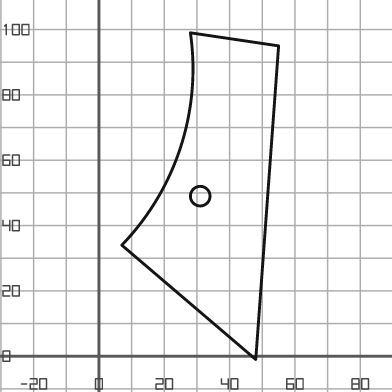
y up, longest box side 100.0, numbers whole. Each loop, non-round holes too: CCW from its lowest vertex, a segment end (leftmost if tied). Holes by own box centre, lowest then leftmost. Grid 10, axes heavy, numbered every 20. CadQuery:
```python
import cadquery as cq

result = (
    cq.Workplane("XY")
    .moveTo(48.0, -1.0)
    .lineTo(55.0, 95.0)
    .lineTo(28.0, 99.0)
    .threePointArc((25.0, 64.0), (7.0, 34.0))
    .close()
    .moveTo(31.0, 49.0)
    .circle(3.0)
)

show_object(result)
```